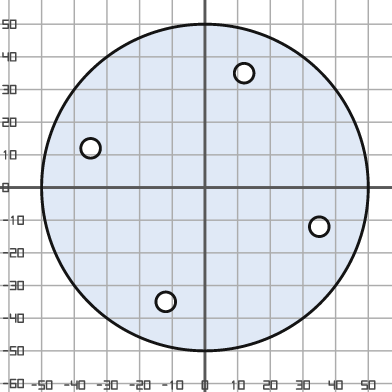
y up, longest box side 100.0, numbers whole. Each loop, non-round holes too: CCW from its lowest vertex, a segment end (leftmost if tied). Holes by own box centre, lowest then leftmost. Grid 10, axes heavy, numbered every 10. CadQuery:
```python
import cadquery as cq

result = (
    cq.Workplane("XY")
    .moveTo(0.0, 0.0)
    .circle(50.0)
    .moveTo(-12.0, -35.0)
    .circle(3.0)
    .moveTo(35.0, -12.0)
    .circle(3.0)
    .moveTo(-35.0, 12.0)
    .circle(3.0)
    .moveTo(12.0, 35.0)
    .circle(3.0)
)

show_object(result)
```